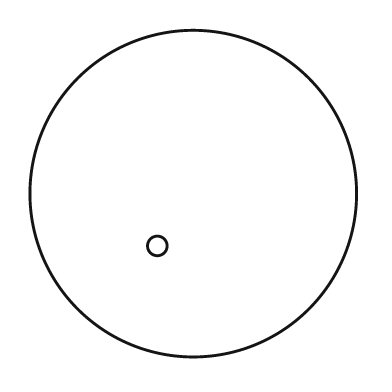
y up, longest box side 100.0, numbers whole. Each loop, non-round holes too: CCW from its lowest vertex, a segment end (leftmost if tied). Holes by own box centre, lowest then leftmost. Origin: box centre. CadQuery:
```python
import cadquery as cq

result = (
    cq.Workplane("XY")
    .moveTo(0.0, 0.0)
    .circle(50.0)
    .moveTo(-11.0, -16.0)
    .circle(3.0)
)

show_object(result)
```